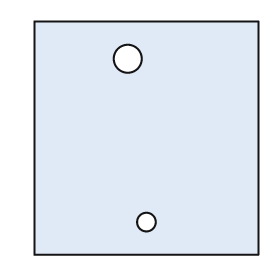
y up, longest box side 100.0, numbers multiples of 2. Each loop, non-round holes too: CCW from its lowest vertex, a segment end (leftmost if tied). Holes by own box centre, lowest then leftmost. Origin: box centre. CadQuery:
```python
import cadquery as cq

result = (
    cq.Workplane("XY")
    .moveTo(-48.0, -50.0)
    .lineTo(48.0, -50.0)
    .lineTo(48.0, 50.0)
    .lineTo(-48.0, 50.0)
    .close()
    .moveTo(0.0, -36.0)
    .circle(4.0)
    .moveTo(-8.0, 34.0)
    .circle(6.0)
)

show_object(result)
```